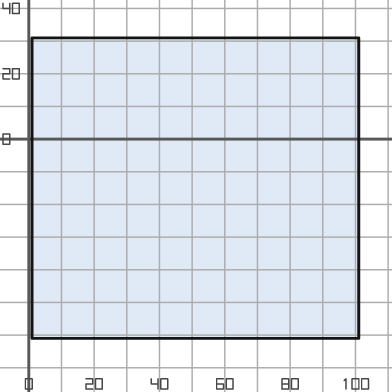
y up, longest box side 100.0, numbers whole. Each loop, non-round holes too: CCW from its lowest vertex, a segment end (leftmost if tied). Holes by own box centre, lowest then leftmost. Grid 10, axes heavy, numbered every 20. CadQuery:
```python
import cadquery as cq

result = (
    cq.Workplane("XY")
    .moveTo(1.0, -61.0)
    .lineTo(101.0, -61.0)
    .lineTo(101.0, 31.0)
    .lineTo(1.0, 31.0)
    .close()
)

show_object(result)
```